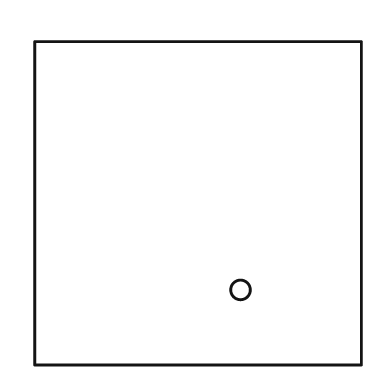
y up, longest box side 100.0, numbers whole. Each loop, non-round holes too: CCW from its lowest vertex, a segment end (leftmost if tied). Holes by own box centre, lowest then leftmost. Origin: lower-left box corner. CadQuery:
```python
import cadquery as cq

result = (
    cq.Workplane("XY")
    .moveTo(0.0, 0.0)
    .lineTo(100.0, 0.0)
    .lineTo(100.0, 99.0)
    .lineTo(0.0, 99.0)
    .close()
    .moveTo(63.0, 23.0)
    .circle(3.0)
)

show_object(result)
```